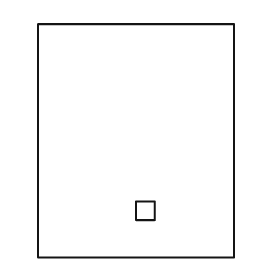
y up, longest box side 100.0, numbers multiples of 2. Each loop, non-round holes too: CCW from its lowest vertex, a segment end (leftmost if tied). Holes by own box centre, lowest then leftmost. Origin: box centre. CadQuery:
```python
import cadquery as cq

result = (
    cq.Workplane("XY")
    .moveTo(-42.0, -50.0)
    .lineTo(42.0, -50.0)
    .lineTo(42.0, 50.0)
    .lineTo(-42.0, 50.0)
    .close()
    .moveTo(0.0, -34.0)
    .lineTo(8.0, -34.0)
    .lineTo(8.0, -26.0)
    .lineTo(0.0, -26.0)
    .close()
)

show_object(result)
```